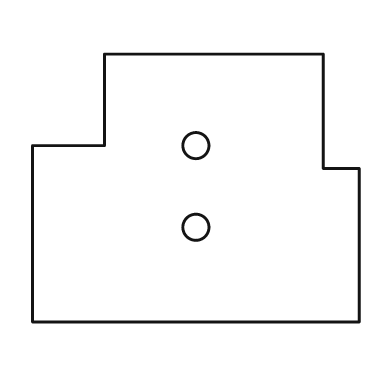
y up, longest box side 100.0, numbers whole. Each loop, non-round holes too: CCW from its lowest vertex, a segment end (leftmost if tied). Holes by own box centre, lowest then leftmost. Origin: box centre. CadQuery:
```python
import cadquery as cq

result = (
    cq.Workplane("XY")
    .moveTo(-50.0, -41.0)
    .lineTo(50.0, -41.0)
    .lineTo(50.0, 6.0)
    .lineTo(39.0, 6.0)
    .lineTo(39.0, 41.0)
    .lineTo(-28.0, 41.0)
    .lineTo(-28.0, 13.0)
    .lineTo(-50.0, 13.0)
    .close()
    .moveTo(0.0, -12.0)
    .circle(4.0)
    .moveTo(0.0, 13.0)
    .circle(4.0)
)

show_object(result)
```